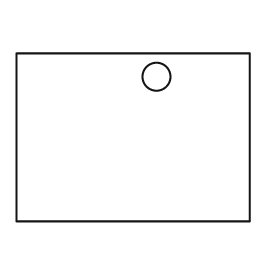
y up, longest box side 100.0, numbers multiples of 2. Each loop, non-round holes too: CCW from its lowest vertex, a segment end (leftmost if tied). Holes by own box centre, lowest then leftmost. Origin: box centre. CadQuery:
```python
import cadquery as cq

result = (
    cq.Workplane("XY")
    .moveTo(-50.0, -36.0)
    .lineTo(50.0, -36.0)
    .lineTo(50.0, 36.0)
    .lineTo(-50.0, 36.0)
    .close()
    .moveTo(10.0, 26.0)
    .circle(6.0)
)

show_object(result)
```